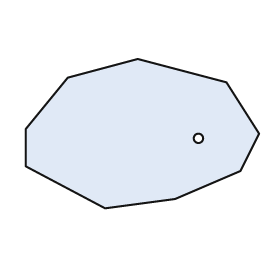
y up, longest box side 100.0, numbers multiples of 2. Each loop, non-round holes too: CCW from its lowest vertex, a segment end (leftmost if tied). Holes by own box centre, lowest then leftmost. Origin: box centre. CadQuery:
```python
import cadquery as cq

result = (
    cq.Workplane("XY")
    .moveTo(-16.0, -32.0)
    .lineTo(14.0, -28.0)
    .lineTo(42.0, -16.0)
    .lineTo(50.0, 0.0)
    .lineTo(36.0, 22.0)
    .lineTo(-2.0, 32.0)
    .lineTo(-32.0, 24.0)
    .lineTo(-50.0, 2.0)
    .lineTo(-50.0, -14.0)
    .close()
    .moveTo(24.0, -2.0)
    .circle(2.0)
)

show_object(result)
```